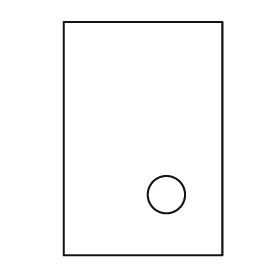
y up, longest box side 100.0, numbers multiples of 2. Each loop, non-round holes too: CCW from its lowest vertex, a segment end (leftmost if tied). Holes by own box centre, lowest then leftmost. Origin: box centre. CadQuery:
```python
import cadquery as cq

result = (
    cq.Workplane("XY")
    .moveTo(-34.0, -50.0)
    .lineTo(34.0, -50.0)
    .lineTo(34.0, 50.0)
    .lineTo(-34.0, 50.0)
    .close()
    .moveTo(10.0, -24.0)
    .circle(8.0)
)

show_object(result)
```